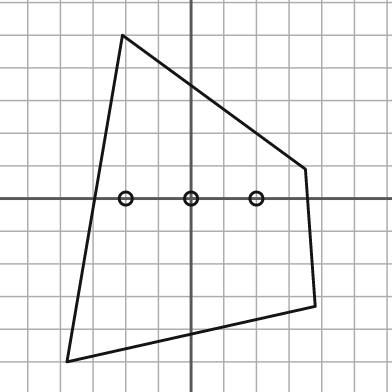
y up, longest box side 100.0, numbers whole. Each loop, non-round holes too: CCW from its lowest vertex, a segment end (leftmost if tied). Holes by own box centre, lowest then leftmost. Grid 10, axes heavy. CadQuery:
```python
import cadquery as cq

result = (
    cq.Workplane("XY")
    .moveTo(-38.0, -50.0)
    .lineTo(38.0, -33.0)
    .lineTo(35.0, 9.0)
    .lineTo(-21.0, 50.0)
    .close()
    .moveTo(-20.0, 0.0)
    .circle(2.0)
    .moveTo(0.0, 0.0)
    .circle(2.0)
    .moveTo(20.0, 0.0)
    .circle(2.0)
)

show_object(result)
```